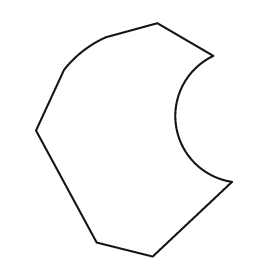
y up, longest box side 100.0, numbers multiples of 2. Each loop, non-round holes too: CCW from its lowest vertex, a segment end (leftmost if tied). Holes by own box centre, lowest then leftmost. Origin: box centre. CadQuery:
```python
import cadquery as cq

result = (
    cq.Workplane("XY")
    .moveTo(8.0, -50.0)
    .lineTo(42.0, -18.0)
    .threePointArc((18.0, 6.0), (34.0, 36.0))
    .lineTo(10.0, 50.0)
    .lineTo(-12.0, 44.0)
    .threePointArc((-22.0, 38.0), (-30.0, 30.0))
    .lineTo(-42.0, 4.0)
    .lineTo(-16.0, -44.0)
    .close()
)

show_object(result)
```